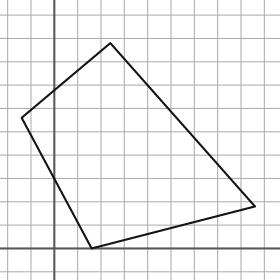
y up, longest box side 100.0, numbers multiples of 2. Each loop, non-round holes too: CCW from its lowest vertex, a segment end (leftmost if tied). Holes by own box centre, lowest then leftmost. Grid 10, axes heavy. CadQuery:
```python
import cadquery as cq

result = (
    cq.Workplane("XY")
    .moveTo(16.0, 0.0)
    .lineTo(86.0, 18.0)
    .lineTo(24.0, 88.0)
    .lineTo(-14.0, 56.0)
    .close()
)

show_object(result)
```